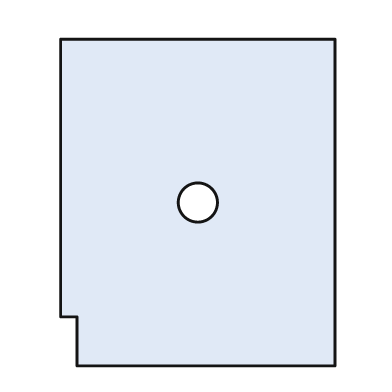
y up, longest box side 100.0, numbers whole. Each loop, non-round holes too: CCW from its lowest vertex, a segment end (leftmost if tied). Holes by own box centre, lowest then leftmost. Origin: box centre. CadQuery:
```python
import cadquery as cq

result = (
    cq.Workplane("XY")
    .moveTo(-37.0, -50.0)
    .lineTo(42.0, -50.0)
    .lineTo(42.0, 50.0)
    .lineTo(-42.0, 50.0)
    .lineTo(-42.0, -35.0)
    .lineTo(-37.0, -35.0)
    .close()
    .moveTo(0.0, 0.0)
    .circle(6.0)
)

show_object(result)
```